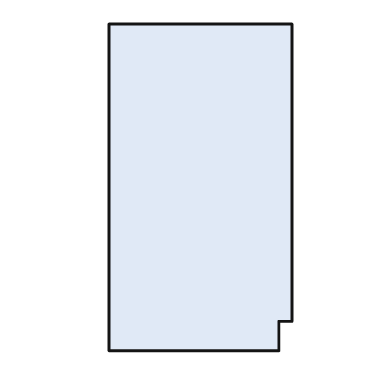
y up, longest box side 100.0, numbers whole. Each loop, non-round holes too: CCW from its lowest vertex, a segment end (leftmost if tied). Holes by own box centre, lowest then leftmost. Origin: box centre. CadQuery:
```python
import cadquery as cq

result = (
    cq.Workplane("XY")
    .moveTo(-28.0, -50.0)
    .lineTo(24.0, -50.0)
    .lineTo(24.0, -41.0)
    .lineTo(28.0, -41.0)
    .lineTo(28.0, 50.0)
    .lineTo(-28.0, 50.0)
    .close()
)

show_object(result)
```